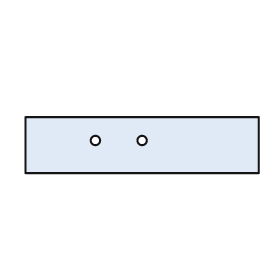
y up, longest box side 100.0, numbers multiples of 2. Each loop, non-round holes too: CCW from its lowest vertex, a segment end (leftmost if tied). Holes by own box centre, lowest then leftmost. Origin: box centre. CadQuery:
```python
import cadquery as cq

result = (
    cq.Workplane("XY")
    .moveTo(-50.0, -12.0)
    .lineTo(50.0, -12.0)
    .lineTo(50.0, 12.0)
    .lineTo(-50.0, 12.0)
    .close()
    .moveTo(-20.0, 2.0)
    .circle(2.0)
    .moveTo(0.0, 2.0)
    .circle(2.0)
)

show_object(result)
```